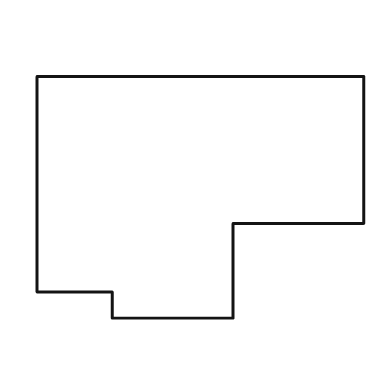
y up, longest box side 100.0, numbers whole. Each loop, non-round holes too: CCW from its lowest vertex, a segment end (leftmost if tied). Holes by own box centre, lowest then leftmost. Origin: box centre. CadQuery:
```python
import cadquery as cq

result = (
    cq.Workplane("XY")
    .moveTo(-27.0, -37.0)
    .lineTo(10.0, -37.0)
    .lineTo(10.0, -8.0)
    .lineTo(50.0, -8.0)
    .lineTo(50.0, 37.0)
    .lineTo(-50.0, 37.0)
    .lineTo(-50.0, -29.0)
    .lineTo(-27.0, -29.0)
    .close()
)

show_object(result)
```